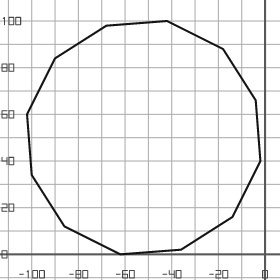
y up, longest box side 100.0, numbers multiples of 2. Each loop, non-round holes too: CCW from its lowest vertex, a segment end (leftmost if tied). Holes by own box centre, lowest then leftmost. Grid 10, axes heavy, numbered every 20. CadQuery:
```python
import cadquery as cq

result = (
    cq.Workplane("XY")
    .moveTo(-62.0, 0.0)
    .lineTo(-36.0, 2.0)
    .lineTo(-14.0, 16.0)
    .lineTo(-2.0, 40.0)
    .lineTo(-4.0, 66.0)
    .lineTo(-18.0, 88.0)
    .lineTo(-42.0, 100.0)
    .lineTo(-68.0, 98.0)
    .lineTo(-90.0, 84.0)
    .lineTo(-102.0, 60.0)
    .lineTo(-100.0, 34.0)
    .lineTo(-86.0, 12.0)
    .close()
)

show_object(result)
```